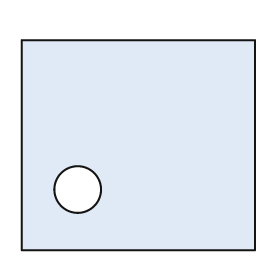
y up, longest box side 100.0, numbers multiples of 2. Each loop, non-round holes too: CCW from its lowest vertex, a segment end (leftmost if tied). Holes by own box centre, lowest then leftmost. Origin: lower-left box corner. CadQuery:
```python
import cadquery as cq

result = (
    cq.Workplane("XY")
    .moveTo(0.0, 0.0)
    .lineTo(100.0, 0.0)
    .lineTo(100.0, 90.0)
    .lineTo(0.0, 90.0)
    .close()
    .moveTo(24.0, 26.0)
    .circle(10.0)
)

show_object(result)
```